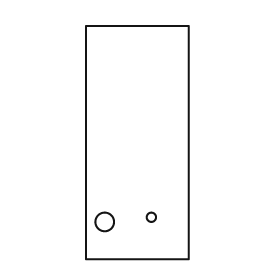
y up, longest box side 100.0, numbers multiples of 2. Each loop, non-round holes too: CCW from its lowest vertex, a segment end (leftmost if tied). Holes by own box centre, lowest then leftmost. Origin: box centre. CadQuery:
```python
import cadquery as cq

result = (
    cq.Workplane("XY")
    .moveTo(-22.0, -50.0)
    .lineTo(22.0, -50.0)
    .lineTo(22.0, 50.0)
    .lineTo(-22.0, 50.0)
    .close()
    .moveTo(-14.0, -34.0)
    .circle(4.0)
    .moveTo(6.0, -32.0)
    .circle(2.0)
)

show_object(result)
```